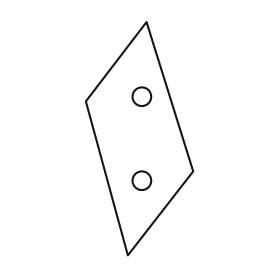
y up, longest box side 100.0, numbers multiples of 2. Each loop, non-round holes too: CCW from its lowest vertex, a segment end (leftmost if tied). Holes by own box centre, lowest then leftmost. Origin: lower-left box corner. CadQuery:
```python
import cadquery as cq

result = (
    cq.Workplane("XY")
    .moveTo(18.0, 0.0)
    .lineTo(46.0, 36.0)
    .lineTo(26.0, 100.0)
    .lineTo(0.0, 66.0)
    .close()
    .moveTo(24.0, 32.0)
    .circle(4.0)
    .moveTo(24.0, 68.0)
    .circle(4.0)
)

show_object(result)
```